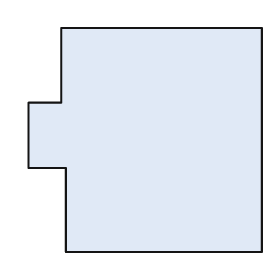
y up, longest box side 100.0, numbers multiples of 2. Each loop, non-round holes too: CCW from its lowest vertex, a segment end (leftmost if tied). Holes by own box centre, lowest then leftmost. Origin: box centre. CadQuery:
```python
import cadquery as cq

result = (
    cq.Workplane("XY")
    .moveTo(-34.0, -48.0)
    .lineTo(50.0, -48.0)
    .lineTo(50.0, 48.0)
    .lineTo(-36.0, 48.0)
    .lineTo(-36.0, 16.0)
    .lineTo(-50.0, 16.0)
    .lineTo(-50.0, -12.0)
    .lineTo(-34.0, -12.0)
    .close()
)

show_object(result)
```